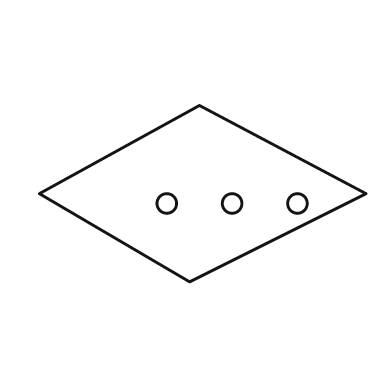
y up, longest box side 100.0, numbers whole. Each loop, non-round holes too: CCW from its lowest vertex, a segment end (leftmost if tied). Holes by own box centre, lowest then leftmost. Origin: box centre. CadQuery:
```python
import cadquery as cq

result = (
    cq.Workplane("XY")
    .moveTo(-4.0, -27.0)
    .lineTo(50.0, 0.0)
    .lineTo(-1.0, 27.0)
    .lineTo(-50.0, 0.0)
    .close()
    .moveTo(-11.0, -3.0)
    .circle(3.0)
    .moveTo(9.0, -3.0)
    .circle(3.0)
    .moveTo(29.0, -3.0)
    .circle(3.0)
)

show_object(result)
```